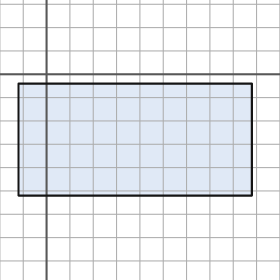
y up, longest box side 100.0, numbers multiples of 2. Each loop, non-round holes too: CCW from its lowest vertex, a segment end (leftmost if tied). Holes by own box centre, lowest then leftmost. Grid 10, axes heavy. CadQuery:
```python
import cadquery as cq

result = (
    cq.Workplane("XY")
    .moveTo(-12.0, -52.0)
    .lineTo(88.0, -52.0)
    .lineTo(88.0, -4.0)
    .lineTo(-12.0, -4.0)
    .close()
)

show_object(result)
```